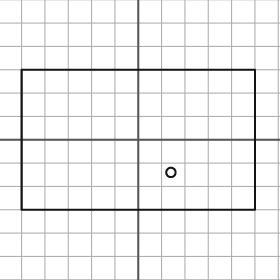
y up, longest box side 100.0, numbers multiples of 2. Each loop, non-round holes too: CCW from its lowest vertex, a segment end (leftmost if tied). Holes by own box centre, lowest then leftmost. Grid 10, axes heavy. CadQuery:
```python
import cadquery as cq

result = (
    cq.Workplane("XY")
    .moveTo(-50.0, -30.0)
    .lineTo(50.0, -30.0)
    .lineTo(50.0, 30.0)
    .lineTo(-50.0, 30.0)
    .close()
    .moveTo(14.0, -14.0)
    .circle(2.0)
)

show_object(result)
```